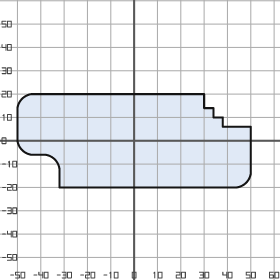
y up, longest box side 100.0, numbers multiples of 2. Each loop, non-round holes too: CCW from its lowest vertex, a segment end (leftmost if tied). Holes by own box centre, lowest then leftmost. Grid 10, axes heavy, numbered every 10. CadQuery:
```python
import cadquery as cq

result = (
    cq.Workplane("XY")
    .moveTo(-32.0, -20.0)
    .lineTo(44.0, -20.0)
    .threePointArc((48.0, -18.0), (50.0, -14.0))
    .lineTo(50.0, 6.0)
    .lineTo(38.0, 6.0)
    .lineTo(38.0, 10.0)
    .lineTo(34.0, 10.0)
    .lineTo(34.0, 14.0)
    .lineTo(30.0, 14.0)
    .lineTo(30.0, 20.0)
    .lineTo(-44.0, 20.0)
    .threePointArc((-48.0, 18.0), (-50.0, 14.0))
    .lineTo(-50.0, 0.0)
    .threePointArc((-48.0, -4.0), (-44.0, -6.0))
    .lineTo(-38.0, -6.0)
    .threePointArc((-34.0, -8.0), (-32.0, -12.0))
    .close()
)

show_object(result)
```